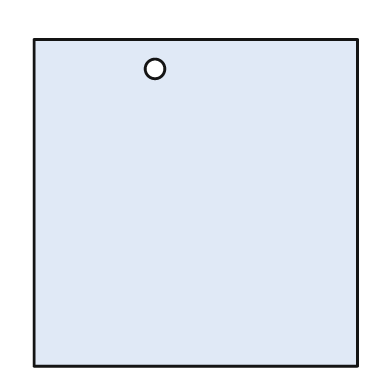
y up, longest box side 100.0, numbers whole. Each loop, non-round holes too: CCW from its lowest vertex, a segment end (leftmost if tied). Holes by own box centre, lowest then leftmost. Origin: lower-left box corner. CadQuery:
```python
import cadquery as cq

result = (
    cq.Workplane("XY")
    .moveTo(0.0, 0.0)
    .lineTo(99.0, 0.0)
    .lineTo(99.0, 100.0)
    .lineTo(0.0, 100.0)
    .close()
    .moveTo(37.0, 91.0)
    .circle(3.0)
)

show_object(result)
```